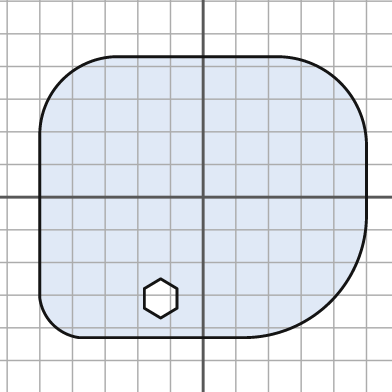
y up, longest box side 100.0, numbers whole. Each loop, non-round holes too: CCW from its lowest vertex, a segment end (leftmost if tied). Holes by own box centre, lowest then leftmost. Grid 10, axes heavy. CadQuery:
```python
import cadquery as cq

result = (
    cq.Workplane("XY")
    .moveTo(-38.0, -43.0)
    .lineTo(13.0, -43.0)
    .threePointArc((39.0, -32.0), (50.0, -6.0))
    .lineTo(50.0, 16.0)
    .threePointArc((42.0, 35.0), (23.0, 43.0))
    .lineTo(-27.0, 43.0)
    .threePointArc((-43.0, 36.0), (-50.0, 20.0))
    .lineTo(-50.0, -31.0)
    .threePointArc((-46.0, -39.0), (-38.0, -43.0))
    .close()
    .moveTo(-13.0, -37.0)
    .lineTo(-8.0, -34.0)
    .lineTo(-8.0, -28.0)
    .lineTo(-13.0, -25.0)
    .lineTo(-18.0, -28.0)
    .lineTo(-18.0, -34.0)
    .close()
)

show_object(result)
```